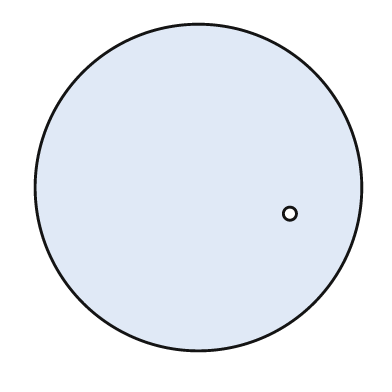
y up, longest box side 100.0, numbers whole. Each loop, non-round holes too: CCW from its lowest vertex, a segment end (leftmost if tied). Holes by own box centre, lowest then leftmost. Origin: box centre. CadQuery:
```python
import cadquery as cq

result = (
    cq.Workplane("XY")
    .moveTo(0.0, 0.0)
    .circle(50.0)
    .moveTo(28.0, -8.0)
    .circle(2.0)
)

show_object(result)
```